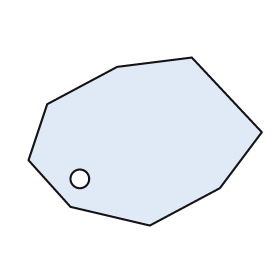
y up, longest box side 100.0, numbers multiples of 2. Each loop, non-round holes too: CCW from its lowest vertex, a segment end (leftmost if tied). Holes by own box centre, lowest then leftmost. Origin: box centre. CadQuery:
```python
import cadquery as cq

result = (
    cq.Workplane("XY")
    .moveTo(2.0, -36.0)
    .lineTo(32.0, -20.0)
    .lineTo(50.0, 4.0)
    .lineTo(20.0, 36.0)
    .lineTo(-12.0, 32.0)
    .lineTo(-42.0, 16.0)
    .lineTo(-50.0, -8.0)
    .lineTo(-32.0, -28.0)
    .close()
    .moveTo(-28.0, -16.0)
    .circle(4.0)
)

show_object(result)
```